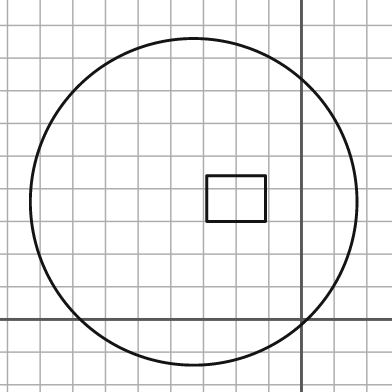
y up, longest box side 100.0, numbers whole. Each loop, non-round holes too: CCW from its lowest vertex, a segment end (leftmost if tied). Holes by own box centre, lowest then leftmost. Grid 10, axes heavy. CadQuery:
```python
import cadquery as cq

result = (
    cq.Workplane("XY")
    .moveTo(-33.0, 36.0)
    .circle(50.0)
    .moveTo(-29.0, 30.0)
    .lineTo(-11.0, 30.0)
    .lineTo(-11.0, 44.0)
    .lineTo(-29.0, 44.0)
    .close()
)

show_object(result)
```